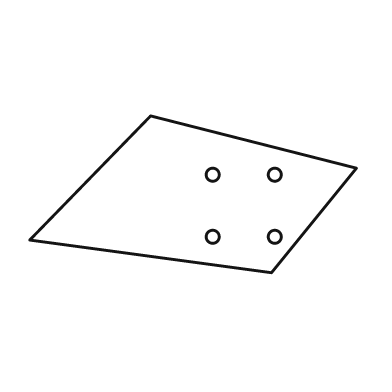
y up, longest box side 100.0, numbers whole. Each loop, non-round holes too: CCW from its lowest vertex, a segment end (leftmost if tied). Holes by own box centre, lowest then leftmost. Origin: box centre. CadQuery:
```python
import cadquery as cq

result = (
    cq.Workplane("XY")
    .moveTo(24.0, -24.0)
    .lineTo(50.0, 8.0)
    .lineTo(-13.0, 24.0)
    .lineTo(-50.0, -14.0)
    .close()
    .moveTo(6.0, -13.0)
    .circle(2.0)
    .moveTo(25.0, -13.0)
    .circle(2.0)
    .moveTo(6.0, 6.0)
    .circle(2.0)
    .moveTo(25.0, 6.0)
    .circle(2.0)
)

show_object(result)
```